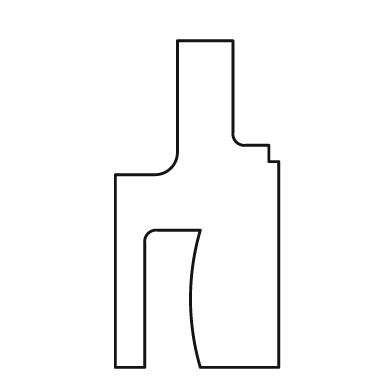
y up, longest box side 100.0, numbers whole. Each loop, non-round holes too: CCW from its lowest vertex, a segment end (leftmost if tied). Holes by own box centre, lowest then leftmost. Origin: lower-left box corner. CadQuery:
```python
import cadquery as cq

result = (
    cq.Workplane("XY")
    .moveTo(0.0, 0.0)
    .lineTo(9.0, 0.0)
    .lineTo(9.0, 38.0)
    .threePointArc((10.0, 41.0), (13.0, 42.0))
    .lineTo(26.0, 42.0)
    .threePointArc((23.0, 21.0), (26.0, 0.0))
    .lineTo(50.0, 0.0)
    .lineTo(50.0, 63.0)
    .lineTo(47.0, 63.0)
    .lineTo(47.0, 68.0)
    .lineTo(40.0, 68.0)
    .threePointArc((37.0, 69.0), (36.0, 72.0))
    .lineTo(36.0, 100.0)
    .lineTo(19.0, 100.0)
    .lineTo(19.0, 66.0)
    .threePointArc((17.0, 61.0), (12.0, 59.0))
    .lineTo(0.0, 59.0)
    .close()
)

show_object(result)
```